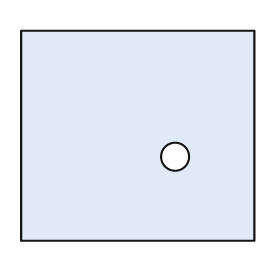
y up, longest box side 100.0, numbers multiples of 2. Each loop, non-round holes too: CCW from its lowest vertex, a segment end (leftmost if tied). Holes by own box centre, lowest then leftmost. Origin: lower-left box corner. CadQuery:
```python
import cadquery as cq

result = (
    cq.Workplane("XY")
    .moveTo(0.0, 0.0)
    .lineTo(100.0, 0.0)
    .lineTo(100.0, 90.0)
    .lineTo(0.0, 90.0)
    .close()
    .moveTo(66.0, 36.0)
    .circle(6.0)
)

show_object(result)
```